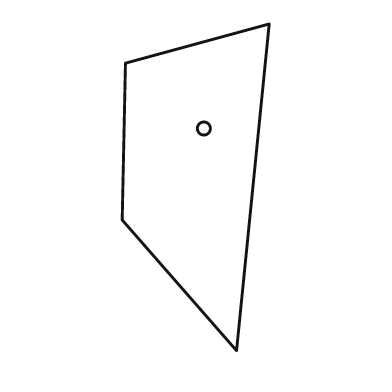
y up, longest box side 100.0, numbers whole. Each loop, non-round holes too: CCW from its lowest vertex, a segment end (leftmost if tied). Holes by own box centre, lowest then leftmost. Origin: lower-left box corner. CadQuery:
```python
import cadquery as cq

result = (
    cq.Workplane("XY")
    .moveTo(35.0, 0.0)
    .lineTo(45.0, 100.0)
    .lineTo(1.0, 88.0)
    .lineTo(0.0, 40.0)
    .close()
    .moveTo(25.0, 68.0)
    .circle(2.0)
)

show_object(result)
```